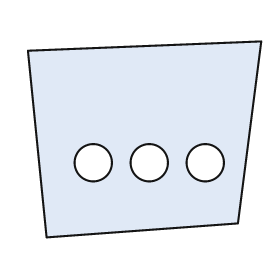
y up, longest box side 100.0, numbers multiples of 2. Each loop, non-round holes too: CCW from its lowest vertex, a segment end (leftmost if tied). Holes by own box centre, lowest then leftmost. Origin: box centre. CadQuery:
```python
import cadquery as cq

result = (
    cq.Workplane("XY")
    .moveTo(-42.0, -42.0)
    .lineTo(40.0, -36.0)
    .lineTo(50.0, 42.0)
    .lineTo(-50.0, 38.0)
    .close()
    .moveTo(-22.0, -10.0)
    .circle(8.0)
    .moveTo(2.0, -10.0)
    .circle(8.0)
    .moveTo(26.0, -10.0)
    .circle(8.0)
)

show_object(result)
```